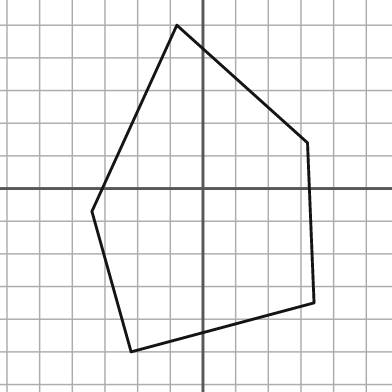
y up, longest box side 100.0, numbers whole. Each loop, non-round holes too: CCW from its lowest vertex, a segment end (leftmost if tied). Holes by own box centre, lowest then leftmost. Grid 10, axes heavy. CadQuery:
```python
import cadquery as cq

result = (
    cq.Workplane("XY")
    .moveTo(-22.0, -50.0)
    .lineTo(34.0, -35.0)
    .lineTo(32.0, 14.0)
    .lineTo(-8.0, 50.0)
    .lineTo(-34.0, -7.0)
    .close()
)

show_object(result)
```